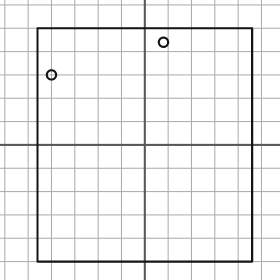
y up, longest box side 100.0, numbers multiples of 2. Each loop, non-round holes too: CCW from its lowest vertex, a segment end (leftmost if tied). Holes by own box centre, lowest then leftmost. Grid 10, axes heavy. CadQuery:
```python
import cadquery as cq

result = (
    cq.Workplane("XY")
    .moveTo(-46.0, -50.0)
    .lineTo(46.0, -50.0)
    .lineTo(46.0, 50.0)
    .lineTo(-46.0, 50.0)
    .close()
    .moveTo(-40.0, 30.0)
    .circle(2.0)
    .moveTo(8.0, 44.0)
    .circle(2.0)
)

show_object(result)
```